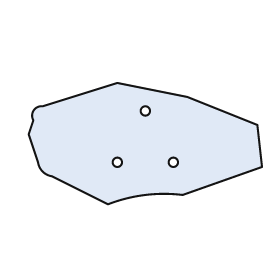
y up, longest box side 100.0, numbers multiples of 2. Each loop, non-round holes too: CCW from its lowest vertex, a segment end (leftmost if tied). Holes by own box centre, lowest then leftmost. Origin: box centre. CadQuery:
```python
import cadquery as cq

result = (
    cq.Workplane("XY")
    .moveTo(-16.0, -26.0)
    .threePointArc((0.0, -22.0), (16.0, -22.0))
    .lineTo(50.0, -10.0)
    .lineTo(48.0, 8.0)
    .lineTo(18.0, 20.0)
    .lineTo(-12.0, 26.0)
    .lineTo(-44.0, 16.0)
    .threePointArc((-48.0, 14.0), (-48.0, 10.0))
    .lineTo(-50.0, 4.0)
    .lineTo(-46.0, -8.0)
    .threePointArc((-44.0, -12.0), (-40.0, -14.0))
    .close()
    .moveTo(-12.0, -8.0)
    .circle(2.0)
    .moveTo(12.0, -8.0)
    .circle(2.0)
    .moveTo(0.0, 14.0)
    .circle(2.0)
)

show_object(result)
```